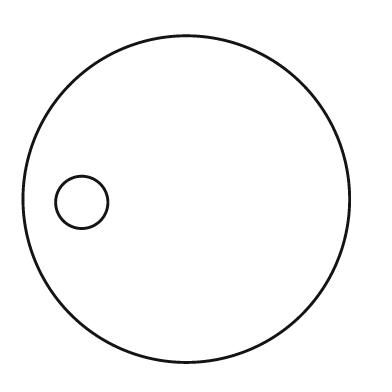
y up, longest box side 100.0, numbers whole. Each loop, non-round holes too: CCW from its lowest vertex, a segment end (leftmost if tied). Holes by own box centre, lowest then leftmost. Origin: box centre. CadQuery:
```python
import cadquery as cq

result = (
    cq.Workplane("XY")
    .moveTo(0.0, 0.0)
    .circle(50.0)
    .moveTo(-32.0, -1.0)
    .circle(8.0)
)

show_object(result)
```